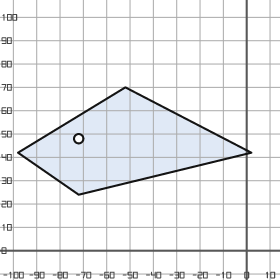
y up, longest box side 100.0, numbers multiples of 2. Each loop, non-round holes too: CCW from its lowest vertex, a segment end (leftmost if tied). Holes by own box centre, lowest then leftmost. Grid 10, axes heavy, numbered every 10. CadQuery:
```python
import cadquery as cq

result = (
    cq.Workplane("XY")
    .moveTo(-72.0, 24.0)
    .lineTo(2.0, 42.0)
    .lineTo(-52.0, 70.0)
    .lineTo(-98.0, 42.0)
    .close()
    .moveTo(-72.0, 48.0)
    .circle(2.0)
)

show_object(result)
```